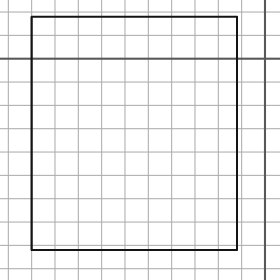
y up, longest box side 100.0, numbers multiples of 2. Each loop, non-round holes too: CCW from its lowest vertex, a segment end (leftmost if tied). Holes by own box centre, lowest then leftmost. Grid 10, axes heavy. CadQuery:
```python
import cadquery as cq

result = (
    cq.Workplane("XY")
    .moveTo(-100.0, -82.0)
    .lineTo(-12.0, -82.0)
    .lineTo(-12.0, 18.0)
    .lineTo(-100.0, 18.0)
    .close()
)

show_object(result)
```